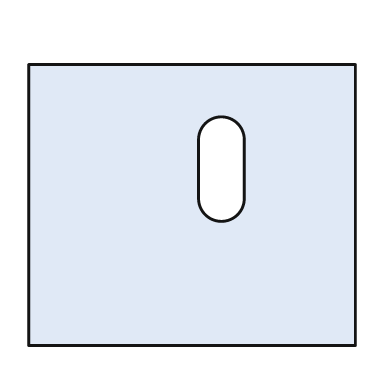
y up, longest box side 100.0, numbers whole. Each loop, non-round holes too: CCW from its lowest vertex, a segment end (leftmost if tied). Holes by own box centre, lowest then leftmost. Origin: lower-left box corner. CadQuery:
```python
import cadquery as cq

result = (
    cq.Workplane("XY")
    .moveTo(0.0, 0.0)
    .lineTo(100.0, 0.0)
    .lineTo(100.0, 86.0)
    .lineTo(0.0, 86.0)
    .close()
    .moveTo(52.0, 45.0)
    .threePointArc((59.0, 38.0), (66.0, 45.0))
    .lineTo(66.0, 63.0)
    .threePointArc((59.0, 70.0), (52.0, 63.0))
    .close()
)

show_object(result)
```